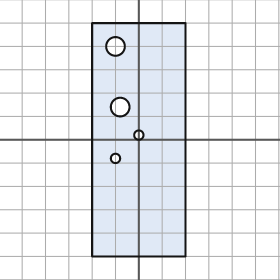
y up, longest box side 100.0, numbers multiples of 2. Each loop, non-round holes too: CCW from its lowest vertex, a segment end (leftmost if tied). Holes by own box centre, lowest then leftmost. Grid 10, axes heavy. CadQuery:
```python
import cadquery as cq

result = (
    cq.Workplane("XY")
    .moveTo(-20.0, -50.0)
    .lineTo(20.0, -50.0)
    .lineTo(20.0, 50.0)
    .lineTo(-20.0, 50.0)
    .close()
    .moveTo(-10.0, -8.0)
    .circle(2.0)
    .moveTo(0.0, 2.0)
    .circle(2.0)
    .moveTo(-8.0, 14.0)
    .circle(4.0)
    .moveTo(-10.0, 40.0)
    .circle(4.0)
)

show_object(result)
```